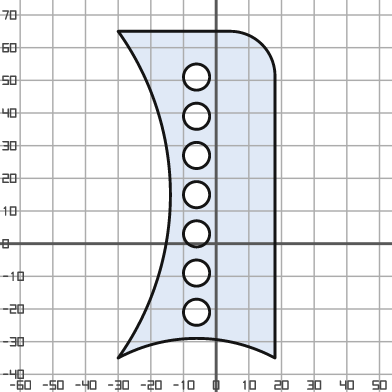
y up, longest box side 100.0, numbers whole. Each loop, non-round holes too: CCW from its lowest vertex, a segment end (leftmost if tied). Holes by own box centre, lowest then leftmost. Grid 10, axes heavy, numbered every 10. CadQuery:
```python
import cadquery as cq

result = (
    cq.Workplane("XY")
    .moveTo(-30.0, -35.0)
    .threePointArc((-6.0, -29.0), (18.0, -35.0))
    .lineTo(18.0, 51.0)
    .threePointArc((14.0, 61.0), (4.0, 65.0))
    .lineTo(-30.0, 65.0)
    .threePointArc((-14.0, 15.0), (-30.0, -35.0))
    .close()
    .moveTo(-6.0, -21.0)
    .circle(4.0)
    .moveTo(-6.0, -9.0)
    .circle(4.0)
    .moveTo(-6.0, 3.0)
    .circle(4.0)
    .moveTo(-6.0, 15.0)
    .circle(4.0)
    .moveTo(-6.0, 27.0)
    .circle(4.0)
    .moveTo(-6.0, 39.0)
    .circle(4.0)
    .moveTo(-6.0, 51.0)
    .circle(4.0)
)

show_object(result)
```